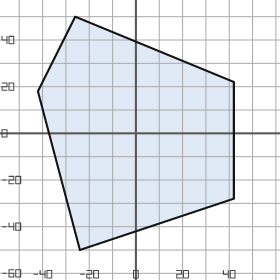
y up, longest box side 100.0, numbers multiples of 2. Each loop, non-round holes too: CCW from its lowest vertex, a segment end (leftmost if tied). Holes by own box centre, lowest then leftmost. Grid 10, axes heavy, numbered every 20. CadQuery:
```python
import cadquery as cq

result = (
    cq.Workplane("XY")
    .moveTo(-24.0, -50.0)
    .lineTo(42.0, -28.0)
    .lineTo(42.0, 22.0)
    .lineTo(-26.0, 50.0)
    .lineTo(-42.0, 18.0)
    .close()
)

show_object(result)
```